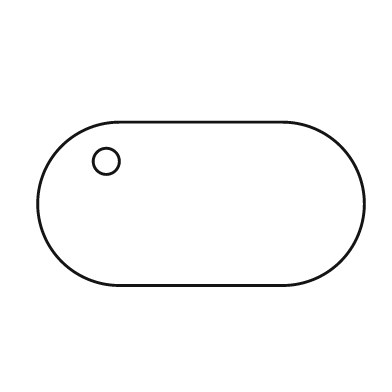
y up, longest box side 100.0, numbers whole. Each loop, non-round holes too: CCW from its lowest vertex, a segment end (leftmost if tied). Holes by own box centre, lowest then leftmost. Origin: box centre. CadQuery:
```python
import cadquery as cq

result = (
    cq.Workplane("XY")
    .moveTo(-25.0, -25.0)
    .lineTo(25.0, -25.0)
    .threePointArc((50.0, 0.0), (25.0, 25.0))
    .lineTo(-25.0, 25.0)
    .threePointArc((-50.0, 0.0), (-25.0, -25.0))
    .close()
    .moveTo(-29.0, 13.0)
    .circle(4.0)
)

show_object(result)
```